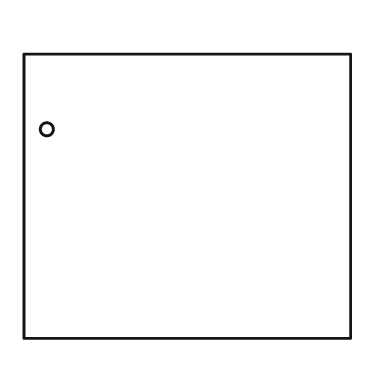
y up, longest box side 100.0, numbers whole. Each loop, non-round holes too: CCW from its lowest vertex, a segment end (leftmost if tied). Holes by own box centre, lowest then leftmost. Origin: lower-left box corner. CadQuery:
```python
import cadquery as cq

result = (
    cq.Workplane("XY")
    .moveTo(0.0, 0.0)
    .lineTo(100.0, 0.0)
    .lineTo(100.0, 87.0)
    .lineTo(0.0, 87.0)
    .close()
    .moveTo(7.0, 64.0)
    .circle(2.0)
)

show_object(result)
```